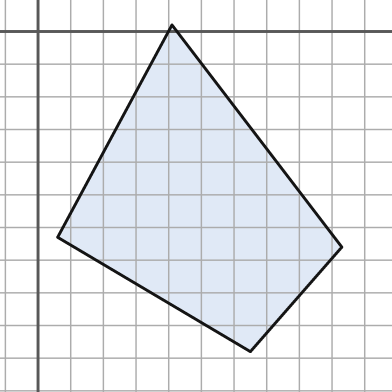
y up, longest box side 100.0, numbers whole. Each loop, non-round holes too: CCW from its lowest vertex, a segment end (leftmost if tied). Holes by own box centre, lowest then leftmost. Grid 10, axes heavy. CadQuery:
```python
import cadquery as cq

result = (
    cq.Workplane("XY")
    .moveTo(65.0, -98.0)
    .lineTo(93.0, -66.0)
    .lineTo(41.0, 2.0)
    .lineTo(6.0, -63.0)
    .close()
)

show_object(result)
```